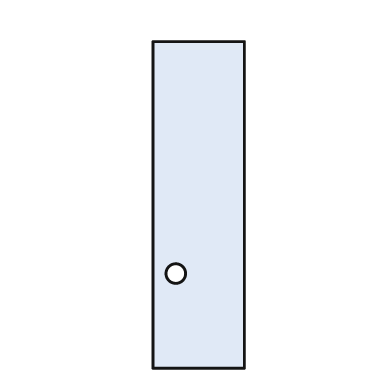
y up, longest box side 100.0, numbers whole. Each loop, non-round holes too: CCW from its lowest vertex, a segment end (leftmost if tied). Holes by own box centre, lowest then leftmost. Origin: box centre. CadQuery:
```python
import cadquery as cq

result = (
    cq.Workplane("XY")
    .moveTo(-14.0, -50.0)
    .lineTo(14.0, -50.0)
    .lineTo(14.0, 50.0)
    .lineTo(-14.0, 50.0)
    .close()
    .moveTo(-7.0, -21.0)
    .circle(3.0)
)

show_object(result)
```